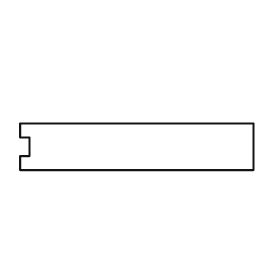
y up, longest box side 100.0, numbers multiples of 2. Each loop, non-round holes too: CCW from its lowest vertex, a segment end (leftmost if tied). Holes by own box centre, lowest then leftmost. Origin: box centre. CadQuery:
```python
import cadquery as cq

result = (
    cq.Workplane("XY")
    .moveTo(-50.0, -10.0)
    .lineTo(50.0, -10.0)
    .lineTo(50.0, 10.0)
    .lineTo(-50.0, 10.0)
    .lineTo(-50.0, 4.0)
    .lineTo(-46.0, 4.0)
    .lineTo(-46.0, -4.0)
    .lineTo(-50.0, -4.0)
    .close()
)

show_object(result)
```